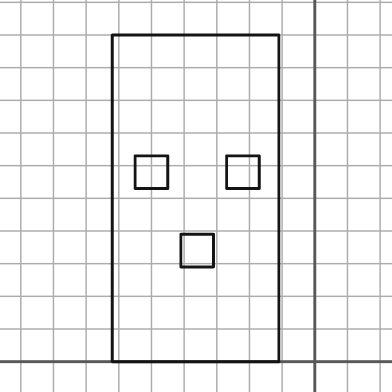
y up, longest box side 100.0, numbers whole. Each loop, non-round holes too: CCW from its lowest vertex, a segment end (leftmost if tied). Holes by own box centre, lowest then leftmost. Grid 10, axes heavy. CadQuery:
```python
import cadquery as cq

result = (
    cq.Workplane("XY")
    .moveTo(-62.0, 0.0)
    .lineTo(-11.0, 0.0)
    .lineTo(-11.0, 100.0)
    .lineTo(-62.0, 100.0)
    .close()
    .moveTo(-41.0, 29.0)
    .lineTo(-31.0, 29.0)
    .lineTo(-31.0, 39.0)
    .lineTo(-41.0, 39.0)
    .close()
    .moveTo(-55.0, 53.0)
    .lineTo(-45.0, 53.0)
    .lineTo(-45.0, 63.0)
    .lineTo(-55.0, 63.0)
    .close()
    .moveTo(-27.0, 53.0)
    .lineTo(-17.0, 53.0)
    .lineTo(-17.0, 63.0)
    .lineTo(-27.0, 63.0)
    .close()
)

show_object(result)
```